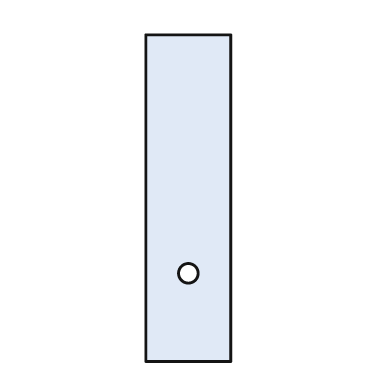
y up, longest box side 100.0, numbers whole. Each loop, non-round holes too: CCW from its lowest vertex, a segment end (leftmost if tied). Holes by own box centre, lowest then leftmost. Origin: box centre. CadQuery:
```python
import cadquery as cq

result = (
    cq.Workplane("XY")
    .moveTo(-13.0, -50.0)
    .lineTo(13.0, -50.0)
    .lineTo(13.0, 50.0)
    .lineTo(-13.0, 50.0)
    .close()
    .moveTo(0.0, -23.0)
    .circle(3.0)
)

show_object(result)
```